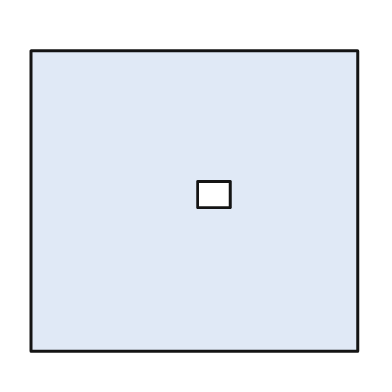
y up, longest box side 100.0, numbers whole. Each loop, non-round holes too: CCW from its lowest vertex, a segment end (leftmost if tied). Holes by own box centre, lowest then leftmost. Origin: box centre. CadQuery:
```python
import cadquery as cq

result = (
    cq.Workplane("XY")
    .moveTo(-50.0, -46.0)
    .lineTo(50.0, -46.0)
    .lineTo(50.0, 46.0)
    .lineTo(-50.0, 46.0)
    .close()
    .moveTo(1.0, -2.0)
    .lineTo(11.0, -2.0)
    .lineTo(11.0, 6.0)
    .lineTo(1.0, 6.0)
    .close()
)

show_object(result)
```